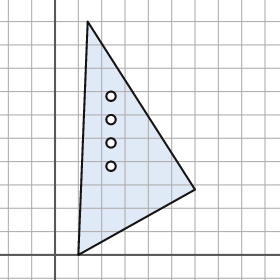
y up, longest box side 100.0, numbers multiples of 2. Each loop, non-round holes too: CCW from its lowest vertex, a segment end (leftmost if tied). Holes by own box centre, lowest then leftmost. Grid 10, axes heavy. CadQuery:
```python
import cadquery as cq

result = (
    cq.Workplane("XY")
    .moveTo(10.0, 0.0)
    .lineTo(60.0, 28.0)
    .lineTo(14.0, 100.0)
    .close()
    .moveTo(24.0, 38.0)
    .circle(2.0)
    .moveTo(24.0, 48.0)
    .circle(2.0)
    .moveTo(24.0, 58.0)
    .circle(2.0)
    .moveTo(24.0, 68.0)
    .circle(2.0)
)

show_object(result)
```